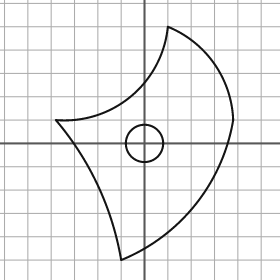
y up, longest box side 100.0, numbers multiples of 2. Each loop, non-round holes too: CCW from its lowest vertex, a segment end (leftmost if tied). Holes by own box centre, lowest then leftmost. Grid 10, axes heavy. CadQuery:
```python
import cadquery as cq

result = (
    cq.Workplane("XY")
    .moveTo(-10.0, -50.0)
    .threePointArc((22.0, -26.0), (38.0, 10.0))
    .threePointArc((30.0, 34.0), (10.0, 50.0))
    .threePointArc((-6.0, 20.0), (-38.0, 10.0))
    .threePointArc((-20.0, -18.0), (-10.0, -50.0))
    .close()
    .moveTo(0.0, 0.0)
    .circle(8.0)
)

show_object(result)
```